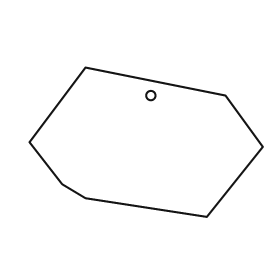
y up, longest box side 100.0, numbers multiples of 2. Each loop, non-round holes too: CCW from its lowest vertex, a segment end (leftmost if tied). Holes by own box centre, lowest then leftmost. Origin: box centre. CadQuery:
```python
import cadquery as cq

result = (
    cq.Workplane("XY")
    .moveTo(26.0, -32.0)
    .lineTo(50.0, -2.0)
    .lineTo(34.0, 20.0)
    .lineTo(-26.0, 32.0)
    .lineTo(-50.0, 0.0)
    .lineTo(-36.0, -18.0)
    .lineTo(-26.0, -24.0)
    .close()
    .moveTo(2.0, 20.0)
    .circle(2.0)
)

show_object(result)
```